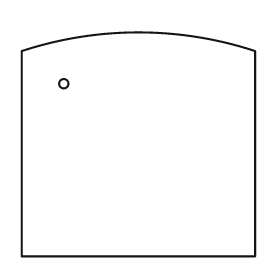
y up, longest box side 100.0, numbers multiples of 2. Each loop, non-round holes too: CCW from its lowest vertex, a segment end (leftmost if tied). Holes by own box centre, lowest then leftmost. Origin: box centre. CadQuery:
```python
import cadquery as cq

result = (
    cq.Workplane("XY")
    .moveTo(-50.0, -48.0)
    .lineTo(50.0, -48.0)
    .lineTo(50.0, 40.0)
    .threePointArc((0.0, 48.0), (-50.0, 40.0))
    .close()
    .moveTo(-32.0, 26.0)
    .circle(2.0)
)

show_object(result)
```